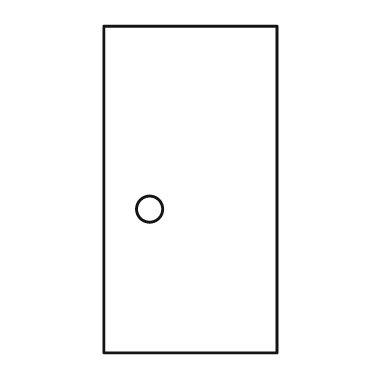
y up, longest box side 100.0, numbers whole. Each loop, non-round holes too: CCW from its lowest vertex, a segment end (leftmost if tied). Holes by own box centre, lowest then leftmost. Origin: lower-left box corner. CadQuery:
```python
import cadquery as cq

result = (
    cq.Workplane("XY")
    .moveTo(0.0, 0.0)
    .lineTo(53.0, 0.0)
    .lineTo(53.0, 100.0)
    .lineTo(0.0, 100.0)
    .close()
    .moveTo(14.0, 44.0)
    .circle(4.0)
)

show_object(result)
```